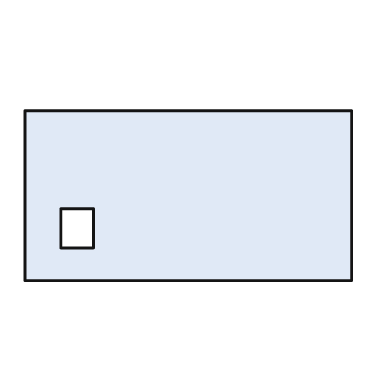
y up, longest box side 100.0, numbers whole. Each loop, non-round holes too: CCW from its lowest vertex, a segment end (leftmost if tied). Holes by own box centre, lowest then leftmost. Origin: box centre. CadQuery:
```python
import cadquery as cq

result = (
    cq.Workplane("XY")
    .moveTo(-50.0, -26.0)
    .lineTo(50.0, -26.0)
    .lineTo(50.0, 26.0)
    .lineTo(-50.0, 26.0)
    .close()
    .moveTo(-39.0, -16.0)
    .lineTo(-29.0, -16.0)
    .lineTo(-29.0, -4.0)
    .lineTo(-39.0, -4.0)
    .close()
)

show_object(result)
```